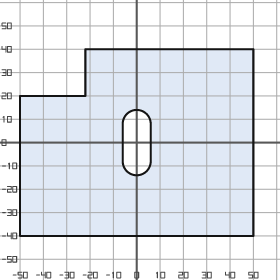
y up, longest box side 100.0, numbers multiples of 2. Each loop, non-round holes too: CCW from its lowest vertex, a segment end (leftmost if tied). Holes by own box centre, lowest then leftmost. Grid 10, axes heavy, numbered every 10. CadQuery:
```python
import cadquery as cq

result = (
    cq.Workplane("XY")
    .moveTo(-50.0, -40.0)
    .lineTo(50.0, -40.0)
    .lineTo(50.0, 40.0)
    .lineTo(-22.0, 40.0)
    .lineTo(-22.0, 20.0)
    .lineTo(-50.0, 20.0)
    .close()
    .moveTo(-6.0, -8.0)
    .threePointArc((0.0, -14.0), (6.0, -8.0))
    .lineTo(6.0, 8.0)
    .threePointArc((0.0, 14.0), (-6.0, 8.0))
    .close()
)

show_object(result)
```